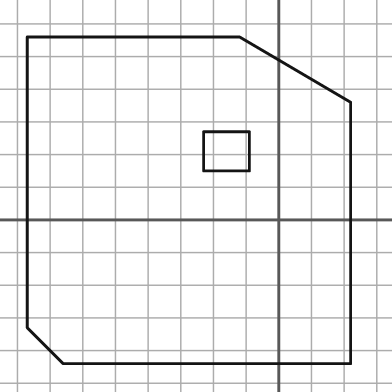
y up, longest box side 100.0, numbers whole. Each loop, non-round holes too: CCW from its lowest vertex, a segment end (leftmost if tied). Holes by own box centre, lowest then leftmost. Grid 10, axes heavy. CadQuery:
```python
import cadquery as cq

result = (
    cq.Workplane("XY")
    .moveTo(-66.0, -44.0)
    .lineTo(22.0, -44.0)
    .lineTo(22.0, 36.0)
    .lineTo(-12.0, 56.0)
    .lineTo(-77.0, 56.0)
    .lineTo(-77.0, -33.0)
    .close()
    .moveTo(-23.0, 15.0)
    .lineTo(-9.0, 15.0)
    .lineTo(-9.0, 27.0)
    .lineTo(-23.0, 27.0)
    .close()
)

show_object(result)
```